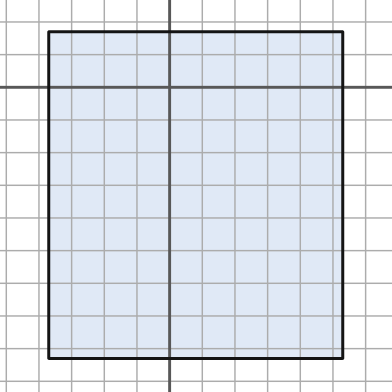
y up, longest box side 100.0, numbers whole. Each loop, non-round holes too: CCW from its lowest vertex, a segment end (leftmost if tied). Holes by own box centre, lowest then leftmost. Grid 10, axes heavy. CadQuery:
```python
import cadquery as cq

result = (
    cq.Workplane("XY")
    .moveTo(-37.0, -83.0)
    .lineTo(53.0, -83.0)
    .lineTo(53.0, 17.0)
    .lineTo(-37.0, 17.0)
    .close()
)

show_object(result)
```